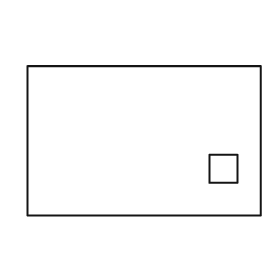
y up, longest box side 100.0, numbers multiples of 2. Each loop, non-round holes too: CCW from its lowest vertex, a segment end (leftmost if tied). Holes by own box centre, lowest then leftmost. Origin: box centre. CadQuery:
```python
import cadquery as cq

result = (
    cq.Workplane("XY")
    .moveTo(-50.0, -32.0)
    .lineTo(50.0, -32.0)
    .lineTo(50.0, 32.0)
    .lineTo(-50.0, 32.0)
    .close()
    .moveTo(28.0, -18.0)
    .lineTo(40.0, -18.0)
    .lineTo(40.0, -6.0)
    .lineTo(28.0, -6.0)
    .close()
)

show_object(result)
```